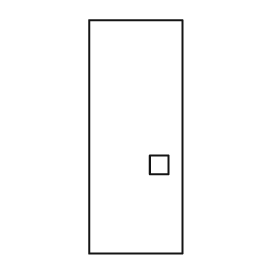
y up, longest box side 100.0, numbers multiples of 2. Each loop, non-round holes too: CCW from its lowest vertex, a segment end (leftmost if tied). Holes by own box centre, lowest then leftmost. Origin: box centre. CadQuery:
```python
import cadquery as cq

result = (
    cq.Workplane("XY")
    .moveTo(-20.0, -50.0)
    .lineTo(20.0, -50.0)
    .lineTo(20.0, 50.0)
    .lineTo(-20.0, 50.0)
    .close()
    .moveTo(6.0, -16.0)
    .lineTo(14.0, -16.0)
    .lineTo(14.0, -8.0)
    .lineTo(6.0, -8.0)
    .close()
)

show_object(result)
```